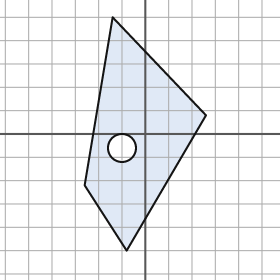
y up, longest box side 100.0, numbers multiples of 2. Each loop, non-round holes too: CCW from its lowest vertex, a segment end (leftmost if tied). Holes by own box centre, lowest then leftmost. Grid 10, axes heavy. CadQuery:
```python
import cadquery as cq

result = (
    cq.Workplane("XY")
    .moveTo(-8.0, -50.0)
    .lineTo(26.0, 8.0)
    .lineTo(-14.0, 50.0)
    .lineTo(-26.0, -22.0)
    .close()
    .moveTo(-10.0, -6.0)
    .circle(6.0)
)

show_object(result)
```